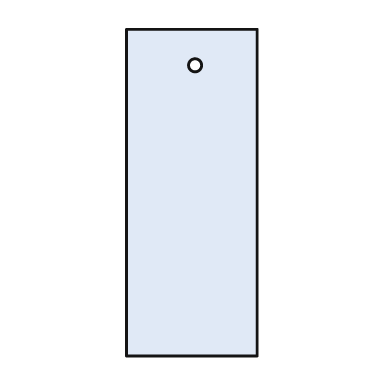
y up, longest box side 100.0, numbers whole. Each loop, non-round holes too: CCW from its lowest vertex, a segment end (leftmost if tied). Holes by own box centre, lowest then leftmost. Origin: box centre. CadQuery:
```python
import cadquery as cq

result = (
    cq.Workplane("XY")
    .moveTo(-20.0, -50.0)
    .lineTo(20.0, -50.0)
    .lineTo(20.0, 50.0)
    .lineTo(-20.0, 50.0)
    .close()
    .moveTo(1.0, 39.0)
    .circle(2.0)
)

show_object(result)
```